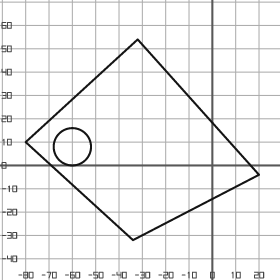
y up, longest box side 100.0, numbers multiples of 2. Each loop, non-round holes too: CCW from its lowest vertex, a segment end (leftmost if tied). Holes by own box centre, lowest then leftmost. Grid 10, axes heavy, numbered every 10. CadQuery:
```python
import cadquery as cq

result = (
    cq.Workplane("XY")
    .moveTo(-34.0, -32.0)
    .lineTo(20.0, -4.0)
    .lineTo(-32.0, 54.0)
    .lineTo(-80.0, 10.0)
    .close()
    .moveTo(-60.0, 8.0)
    .circle(8.0)
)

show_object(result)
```